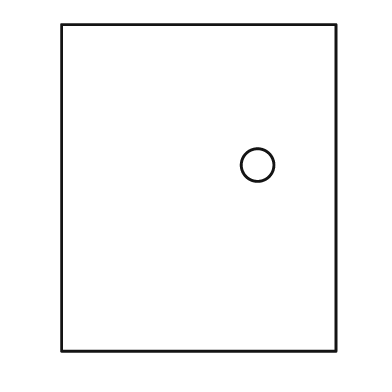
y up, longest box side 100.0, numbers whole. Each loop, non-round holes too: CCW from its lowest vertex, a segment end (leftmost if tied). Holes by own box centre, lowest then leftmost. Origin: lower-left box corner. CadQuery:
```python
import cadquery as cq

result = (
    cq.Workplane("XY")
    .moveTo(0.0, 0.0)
    .lineTo(84.0, 0.0)
    .lineTo(84.0, 100.0)
    .lineTo(0.0, 100.0)
    .close()
    .moveTo(60.0, 57.0)
    .circle(5.0)
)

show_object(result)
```